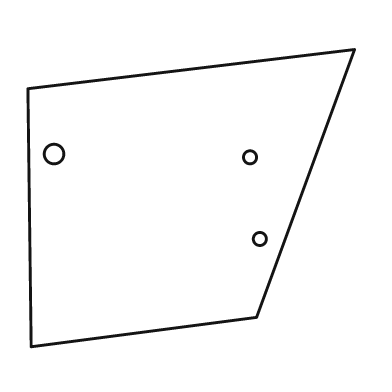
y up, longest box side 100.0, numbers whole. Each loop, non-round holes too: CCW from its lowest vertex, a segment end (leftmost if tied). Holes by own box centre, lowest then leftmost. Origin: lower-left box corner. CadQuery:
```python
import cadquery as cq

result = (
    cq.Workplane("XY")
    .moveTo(1.0, 0.0)
    .lineTo(70.0, 9.0)
    .lineTo(100.0, 91.0)
    .lineTo(0.0, 79.0)
    .close()
    .moveTo(71.0, 33.0)
    .circle(2.0)
    .moveTo(68.0, 58.0)
    .circle(2.0)
    .moveTo(8.0, 59.0)
    .circle(3.0)
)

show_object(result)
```